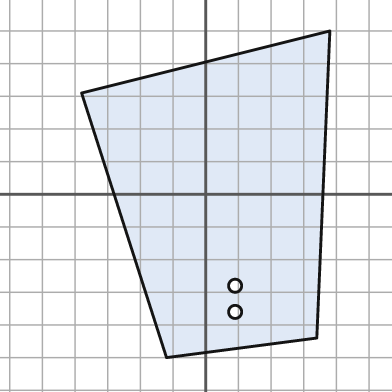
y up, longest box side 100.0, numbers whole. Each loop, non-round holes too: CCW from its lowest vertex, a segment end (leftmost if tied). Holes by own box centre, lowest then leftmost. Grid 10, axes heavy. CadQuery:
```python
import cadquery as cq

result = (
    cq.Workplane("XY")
    .moveTo(-12.0, -50.0)
    .lineTo(34.0, -44.0)
    .lineTo(38.0, 50.0)
    .lineTo(-38.0, 31.0)
    .close()
    .moveTo(9.0, -36.0)
    .circle(2.0)
    .moveTo(9.0, -28.0)
    .circle(2.0)
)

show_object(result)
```